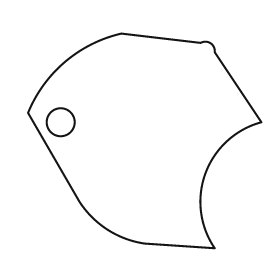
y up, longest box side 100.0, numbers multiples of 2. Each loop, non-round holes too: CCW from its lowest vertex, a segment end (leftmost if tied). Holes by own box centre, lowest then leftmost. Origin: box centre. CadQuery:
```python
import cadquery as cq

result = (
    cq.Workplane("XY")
    .moveTo(30.0, -46.0)
    .threePointArc((26.0, -14.0), (50.0, 8.0))
    .lineTo(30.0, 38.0)
    .threePointArc((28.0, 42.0), (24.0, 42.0))
    .lineTo(-10.0, 46.0)
    .threePointArc((-34.0, 34.0), (-50.0, 12.0))
    .lineTo(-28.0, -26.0)
    .threePointArc((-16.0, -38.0), (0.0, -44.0))
    .close()
    .moveTo(-36.0, 8.0)
    .circle(6.0)
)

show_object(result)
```